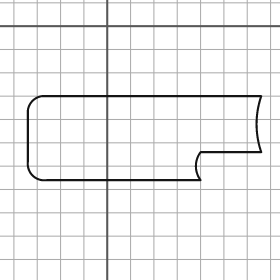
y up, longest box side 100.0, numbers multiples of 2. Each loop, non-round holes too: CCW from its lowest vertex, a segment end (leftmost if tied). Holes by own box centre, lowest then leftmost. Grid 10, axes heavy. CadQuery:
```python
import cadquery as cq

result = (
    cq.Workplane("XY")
    .moveTo(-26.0, -66.0)
    .lineTo(40.0, -66.0)
    .threePointArc((38.0, -60.0), (40.0, -54.0))
    .lineTo(66.0, -54.0)
    .threePointArc((64.0, -42.0), (66.0, -30.0))
    .lineTo(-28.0, -30.0)
    .threePointArc((-32.0, -32.0), (-34.0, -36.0))
    .lineTo(-34.0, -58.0)
    .threePointArc((-32.0, -64.0), (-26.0, -66.0))
    .close()
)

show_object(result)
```